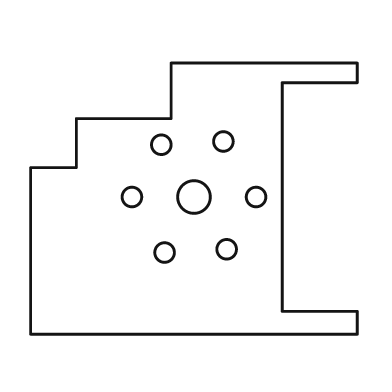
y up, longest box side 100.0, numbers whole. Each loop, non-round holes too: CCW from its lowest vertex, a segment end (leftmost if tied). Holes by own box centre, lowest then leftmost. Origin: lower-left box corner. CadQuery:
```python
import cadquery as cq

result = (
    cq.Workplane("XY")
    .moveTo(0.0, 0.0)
    .lineTo(100.0, 0.0)
    .lineTo(100.0, 7.0)
    .lineTo(77.0, 7.0)
    .lineTo(77.0, 77.0)
    .lineTo(100.0, 77.0)
    .lineTo(100.0, 83.0)
    .lineTo(43.0, 83.0)
    .lineTo(43.0, 66.0)
    .lineTo(14.0, 66.0)
    .lineTo(14.0, 51.0)
    .lineTo(0.0, 51.0)
    .close()
    .moveTo(41.0, 25.0)
    .circle(3.0)
    .moveTo(60.0, 26.0)
    .circle(3.0)
    .moveTo(31.0, 42.0)
    .circle(3.0)
    .moveTo(50.0, 42.0)
    .circle(5.0)
    .moveTo(69.0, 42.0)
    .circle(3.0)
    .moveTo(40.0, 58.0)
    .circle(3.0)
    .moveTo(59.0, 59.0)
    .circle(3.0)
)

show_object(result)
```